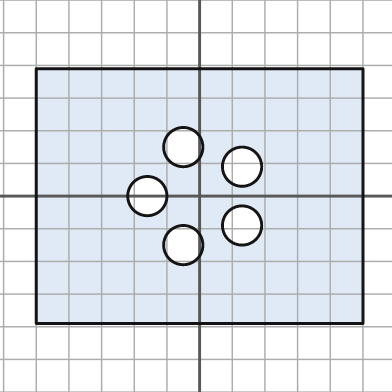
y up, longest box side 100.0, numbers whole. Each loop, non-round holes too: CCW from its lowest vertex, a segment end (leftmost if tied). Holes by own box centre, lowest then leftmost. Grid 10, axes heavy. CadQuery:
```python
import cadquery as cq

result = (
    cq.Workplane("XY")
    .moveTo(-50.0, -39.0)
    .lineTo(50.0, -39.0)
    .lineTo(50.0, 39.0)
    .lineTo(-50.0, 39.0)
    .close()
    .moveTo(-5.0, -15.0)
    .circle(6.0)
    .moveTo(13.0, -9.0)
    .circle(6.0)
    .moveTo(-16.0, 0.0)
    .circle(6.0)
    .moveTo(13.0, 9.0)
    .circle(6.0)
    .moveTo(-5.0, 15.0)
    .circle(6.0)
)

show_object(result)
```